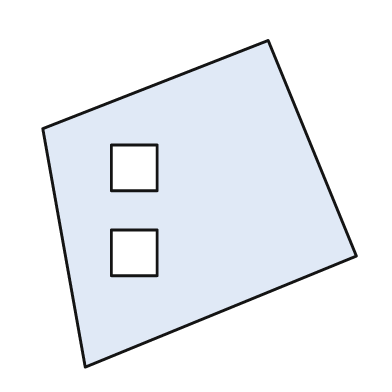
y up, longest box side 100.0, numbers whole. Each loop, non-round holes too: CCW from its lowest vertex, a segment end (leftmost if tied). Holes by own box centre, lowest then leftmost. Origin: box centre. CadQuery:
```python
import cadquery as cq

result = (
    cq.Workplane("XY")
    .moveTo(-35.0, -50.0)
    .lineTo(48.0, -16.0)
    .lineTo(21.0, 50.0)
    .lineTo(-48.0, 23.0)
    .close()
    .moveTo(-27.0, -22.0)
    .lineTo(-13.0, -22.0)
    .lineTo(-13.0, -8.0)
    .lineTo(-27.0, -8.0)
    .close()
    .moveTo(-27.0, 4.0)
    .lineTo(-13.0, 4.0)
    .lineTo(-13.0, 18.0)
    .lineTo(-27.0, 18.0)
    .close()
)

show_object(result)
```